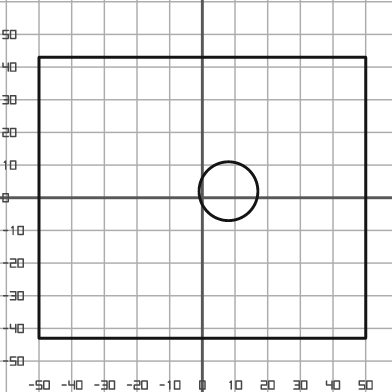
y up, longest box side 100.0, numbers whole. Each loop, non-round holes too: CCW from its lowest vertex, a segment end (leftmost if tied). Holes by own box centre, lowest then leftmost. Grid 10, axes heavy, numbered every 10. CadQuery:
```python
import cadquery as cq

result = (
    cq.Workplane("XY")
    .moveTo(-50.0, -43.0)
    .lineTo(50.0, -43.0)
    .lineTo(50.0, 43.0)
    .lineTo(-50.0, 43.0)
    .close()
    .moveTo(8.0, 2.0)
    .circle(9.0)
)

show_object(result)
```